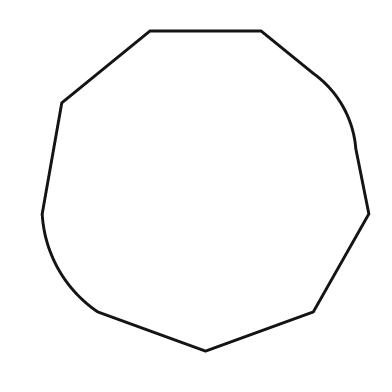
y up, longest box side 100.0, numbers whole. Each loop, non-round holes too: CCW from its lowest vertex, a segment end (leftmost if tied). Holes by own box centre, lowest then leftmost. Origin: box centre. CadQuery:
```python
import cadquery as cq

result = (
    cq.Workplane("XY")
    .moveTo(0.0, -49.0)
    .lineTo(33.0, -37.0)
    .lineTo(50.0, -7.0)
    .lineTo(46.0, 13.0)
    .threePointArc((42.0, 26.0), (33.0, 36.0))
    .lineTo(17.0, 49.0)
    .lineTo(-17.0, 49.0)
    .lineTo(-44.0, 27.0)
    .lineTo(-50.0, -7.0)
    .threePointArc((-45.0, -24.0), (-33.0, -37.0))
    .close()
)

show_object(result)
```